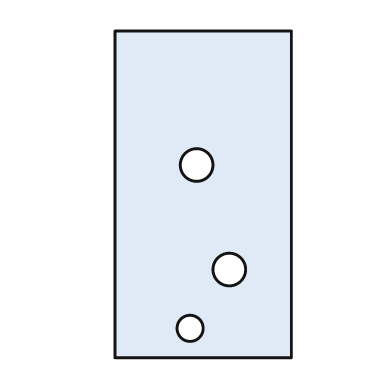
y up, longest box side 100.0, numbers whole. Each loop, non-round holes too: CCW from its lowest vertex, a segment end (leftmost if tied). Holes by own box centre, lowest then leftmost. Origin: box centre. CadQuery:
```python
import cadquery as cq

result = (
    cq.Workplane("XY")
    .moveTo(-27.0, -50.0)
    .lineTo(27.0, -50.0)
    .lineTo(27.0, 50.0)
    .lineTo(-27.0, 50.0)
    .close()
    .moveTo(-4.0, -41.0)
    .circle(4.0)
    .moveTo(8.0, -23.0)
    .circle(5.0)
    .moveTo(-2.0, 9.0)
    .circle(5.0)
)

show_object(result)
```